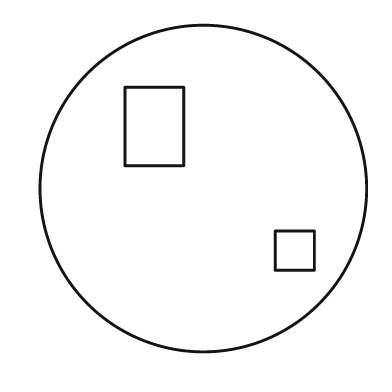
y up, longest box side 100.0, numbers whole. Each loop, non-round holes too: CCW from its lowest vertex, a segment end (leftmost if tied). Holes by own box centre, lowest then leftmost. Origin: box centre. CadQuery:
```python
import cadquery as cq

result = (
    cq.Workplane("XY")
    .moveTo(0.0, 0.0)
    .circle(50.0)
    .moveTo(22.0, -25.0)
    .lineTo(34.0, -25.0)
    .lineTo(34.0, -13.0)
    .lineTo(22.0, -13.0)
    .close()
    .moveTo(-24.0, 7.0)
    .lineTo(-6.0, 7.0)
    .lineTo(-6.0, 31.0)
    .lineTo(-24.0, 31.0)
    .close()
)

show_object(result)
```